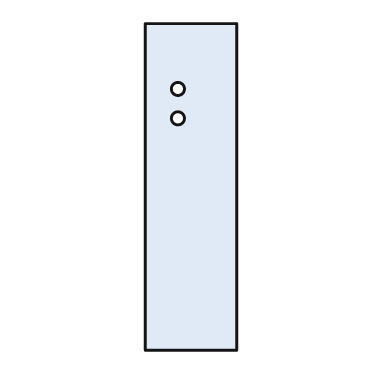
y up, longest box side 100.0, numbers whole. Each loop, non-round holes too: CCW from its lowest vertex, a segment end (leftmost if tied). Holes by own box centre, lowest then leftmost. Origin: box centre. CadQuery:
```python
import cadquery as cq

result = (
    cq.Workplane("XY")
    .moveTo(-14.0, -50.0)
    .lineTo(14.0, -50.0)
    .lineTo(14.0, 50.0)
    .lineTo(-14.0, 50.0)
    .close()
    .moveTo(-4.0, 21.0)
    .circle(2.0)
    .moveTo(-4.0, 30.0)
    .circle(2.0)
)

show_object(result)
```